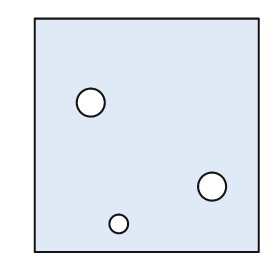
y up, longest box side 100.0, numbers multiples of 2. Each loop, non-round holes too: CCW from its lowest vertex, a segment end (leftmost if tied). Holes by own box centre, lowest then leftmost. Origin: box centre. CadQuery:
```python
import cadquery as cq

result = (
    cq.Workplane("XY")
    .moveTo(-48.0, -50.0)
    .lineTo(48.0, -50.0)
    .lineTo(48.0, 50.0)
    .lineTo(-48.0, 50.0)
    .close()
    .moveTo(-12.0, -38.0)
    .circle(4.0)
    .moveTo(28.0, -22.0)
    .circle(6.0)
    .moveTo(-24.0, 14.0)
    .circle(6.0)
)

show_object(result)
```